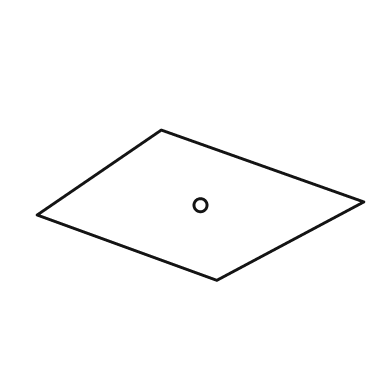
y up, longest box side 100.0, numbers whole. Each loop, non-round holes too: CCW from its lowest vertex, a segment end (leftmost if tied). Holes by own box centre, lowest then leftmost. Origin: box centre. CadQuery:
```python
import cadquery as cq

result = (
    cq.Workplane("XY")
    .moveTo(5.0, -23.0)
    .lineTo(50.0, 1.0)
    .lineTo(-12.0, 23.0)
    .lineTo(-50.0, -3.0)
    .close()
    .moveTo(0.0, 0.0)
    .circle(2.0)
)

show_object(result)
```